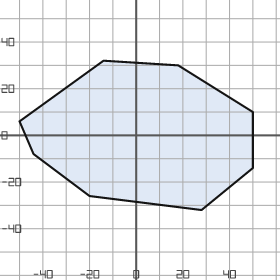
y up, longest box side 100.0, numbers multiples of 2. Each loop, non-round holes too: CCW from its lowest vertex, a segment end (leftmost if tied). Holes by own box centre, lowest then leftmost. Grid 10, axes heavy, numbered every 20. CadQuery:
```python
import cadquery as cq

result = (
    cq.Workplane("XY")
    .moveTo(28.0, -32.0)
    .lineTo(50.0, -14.0)
    .lineTo(50.0, 10.0)
    .lineTo(18.0, 30.0)
    .lineTo(-14.0, 32.0)
    .lineTo(-50.0, 6.0)
    .lineTo(-44.0, -8.0)
    .lineTo(-20.0, -26.0)
    .close()
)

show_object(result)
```